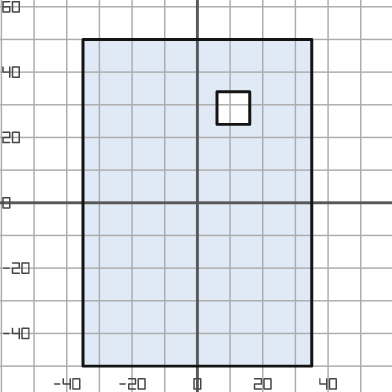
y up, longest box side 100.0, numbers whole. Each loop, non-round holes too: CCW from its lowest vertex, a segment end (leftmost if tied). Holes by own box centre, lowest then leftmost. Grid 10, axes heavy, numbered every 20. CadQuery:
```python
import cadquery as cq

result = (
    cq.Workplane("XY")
    .moveTo(-35.0, -50.0)
    .lineTo(35.0, -50.0)
    .lineTo(35.0, 50.0)
    .lineTo(-35.0, 50.0)
    .close()
    .moveTo(6.0, 24.0)
    .lineTo(16.0, 24.0)
    .lineTo(16.0, 34.0)
    .lineTo(6.0, 34.0)
    .close()
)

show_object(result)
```